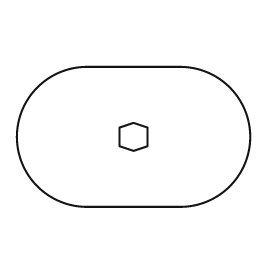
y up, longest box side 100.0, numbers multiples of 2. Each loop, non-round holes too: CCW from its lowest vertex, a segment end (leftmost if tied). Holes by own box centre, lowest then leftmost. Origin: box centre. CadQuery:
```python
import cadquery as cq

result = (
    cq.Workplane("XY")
    .moveTo(-20.0, -30.0)
    .lineTo(20.0, -30.0)
    .threePointArc((50.0, 0.0), (20.0, 30.0))
    .lineTo(-20.0, 30.0)
    .threePointArc((-50.0, 0.0), (-20.0, -30.0))
    .close()
    .moveTo(0.0, -6.0)
    .lineTo(6.0, -4.0)
    .lineTo(6.0, 4.0)
    .lineTo(0.0, 6.0)
    .lineTo(-6.0, 4.0)
    .lineTo(-6.0, -4.0)
    .close()
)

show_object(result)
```